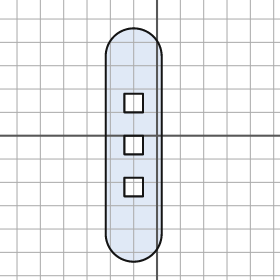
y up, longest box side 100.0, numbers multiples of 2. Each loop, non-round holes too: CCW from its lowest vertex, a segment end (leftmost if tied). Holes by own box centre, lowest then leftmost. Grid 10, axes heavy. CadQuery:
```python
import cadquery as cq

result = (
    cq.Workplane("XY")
    .moveTo(-22.0, -42.0)
    .threePointArc((-10.0, -54.0), (2.0, -42.0))
    .lineTo(2.0, 34.0)
    .threePointArc((-10.0, 46.0), (-22.0, 34.0))
    .close()
    .moveTo(-14.0, -26.0)
    .lineTo(-6.0, -26.0)
    .lineTo(-6.0, -18.0)
    .lineTo(-14.0, -18.0)
    .close()
    .moveTo(-14.0, -8.0)
    .lineTo(-6.0, -8.0)
    .lineTo(-6.0, 0.0)
    .lineTo(-14.0, 0.0)
    .close()
    .moveTo(-14.0, 10.0)
    .lineTo(-6.0, 10.0)
    .lineTo(-6.0, 18.0)
    .lineTo(-14.0, 18.0)
    .close()
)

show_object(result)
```